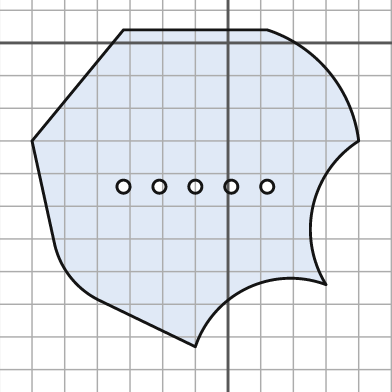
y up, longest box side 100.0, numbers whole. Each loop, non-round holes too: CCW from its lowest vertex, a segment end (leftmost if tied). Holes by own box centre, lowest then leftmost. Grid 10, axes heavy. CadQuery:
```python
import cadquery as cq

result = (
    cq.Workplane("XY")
    .moveTo(-10.0, -93.0)
    .threePointArc((6.0, -75.0), (30.0, -74.0))
    .threePointArc((26.0, -50.0), (40.0, -30.0))
    .threePointArc((31.0, -9.0), (12.0, 4.0))
    .lineTo(-32.0, 4.0)
    .lineTo(-60.0, -30.0)
    .lineTo(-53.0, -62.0)
    .threePointArc((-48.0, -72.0), (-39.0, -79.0))
    .close()
    .moveTo(-32.0, -44.0)
    .circle(2.0)
    .moveTo(-21.0, -44.0)
    .circle(2.0)
    .moveTo(-10.0, -44.0)
    .circle(2.0)
    .moveTo(1.0, -44.0)
    .circle(2.0)
    .moveTo(12.0, -44.0)
    .circle(2.0)
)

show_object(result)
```